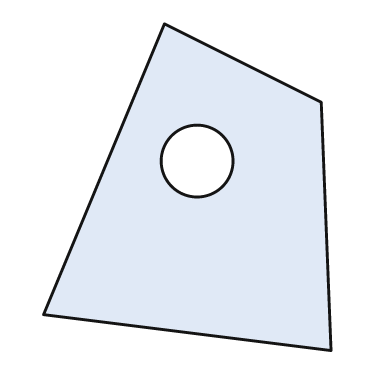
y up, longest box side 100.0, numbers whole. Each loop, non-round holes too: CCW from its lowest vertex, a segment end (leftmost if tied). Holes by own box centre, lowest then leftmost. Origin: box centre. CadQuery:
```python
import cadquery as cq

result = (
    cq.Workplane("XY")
    .moveTo(44.0, -50.0)
    .lineTo(41.0, 26.0)
    .lineTo(-7.0, 50.0)
    .lineTo(-44.0, -39.0)
    .close()
    .moveTo(3.0, 8.0)
    .circle(11.0)
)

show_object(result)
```